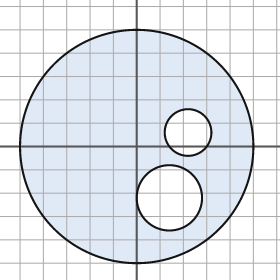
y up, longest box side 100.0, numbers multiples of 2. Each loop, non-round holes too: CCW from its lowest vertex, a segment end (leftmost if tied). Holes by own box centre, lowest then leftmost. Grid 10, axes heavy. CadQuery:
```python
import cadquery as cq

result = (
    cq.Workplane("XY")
    .moveTo(0.0, 0.0)
    .circle(50.0)
    .moveTo(14.0, -22.0)
    .circle(14.0)
    .moveTo(22.0, 6.0)
    .circle(10.0)
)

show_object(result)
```